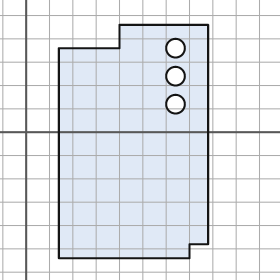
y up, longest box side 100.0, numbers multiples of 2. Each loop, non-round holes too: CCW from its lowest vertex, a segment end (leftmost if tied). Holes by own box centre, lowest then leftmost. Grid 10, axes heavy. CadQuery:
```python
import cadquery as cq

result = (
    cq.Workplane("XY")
    .moveTo(14.0, -54.0)
    .lineTo(70.0, -54.0)
    .lineTo(70.0, -48.0)
    .lineTo(78.0, -48.0)
    .lineTo(78.0, 46.0)
    .lineTo(40.0, 46.0)
    .lineTo(40.0, 36.0)
    .lineTo(14.0, 36.0)
    .close()
    .moveTo(64.0, 12.0)
    .circle(4.0)
    .moveTo(64.0, 24.0)
    .circle(4.0)
    .moveTo(64.0, 36.0)
    .circle(4.0)
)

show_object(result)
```